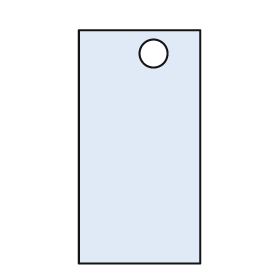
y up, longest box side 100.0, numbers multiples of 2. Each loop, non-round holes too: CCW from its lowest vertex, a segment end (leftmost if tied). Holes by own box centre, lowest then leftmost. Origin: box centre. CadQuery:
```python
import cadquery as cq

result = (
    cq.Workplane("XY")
    .moveTo(-26.0, -50.0)
    .lineTo(26.0, -50.0)
    .lineTo(26.0, 50.0)
    .lineTo(-26.0, 50.0)
    .close()
    .moveTo(6.0, 40.0)
    .circle(6.0)
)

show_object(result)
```